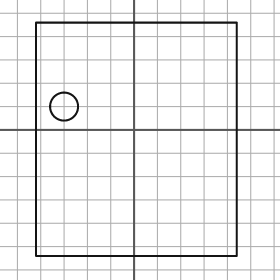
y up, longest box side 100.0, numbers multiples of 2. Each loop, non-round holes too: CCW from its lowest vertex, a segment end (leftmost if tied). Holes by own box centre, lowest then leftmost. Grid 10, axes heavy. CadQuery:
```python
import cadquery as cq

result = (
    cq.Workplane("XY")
    .moveTo(-42.0, -54.0)
    .lineTo(44.0, -54.0)
    .lineTo(44.0, 46.0)
    .lineTo(-42.0, 46.0)
    .close()
    .moveTo(-30.0, 10.0)
    .circle(6.0)
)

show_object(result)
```